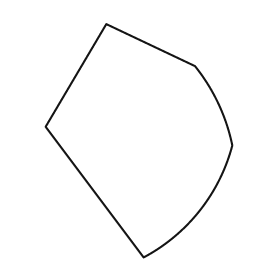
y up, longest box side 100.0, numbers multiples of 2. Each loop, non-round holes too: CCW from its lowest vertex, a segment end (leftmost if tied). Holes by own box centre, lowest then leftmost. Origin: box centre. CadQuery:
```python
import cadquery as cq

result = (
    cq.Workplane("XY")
    .moveTo(2.0, -50.0)
    .threePointArc((26.0, -30.0), (40.0, -2.0))
    .threePointArc((34.0, 16.0), (24.0, 32.0))
    .lineTo(-14.0, 50.0)
    .lineTo(-40.0, 6.0)
    .close()
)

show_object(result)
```